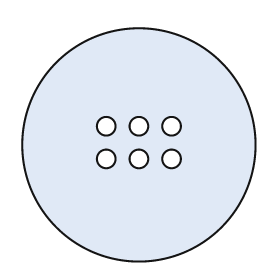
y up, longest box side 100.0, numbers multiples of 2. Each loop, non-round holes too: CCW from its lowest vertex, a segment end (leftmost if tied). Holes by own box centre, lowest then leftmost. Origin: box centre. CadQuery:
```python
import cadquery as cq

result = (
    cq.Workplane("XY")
    .moveTo(0.0, 0.0)
    .circle(50.0)
    .moveTo(-14.0, -6.0)
    .circle(4.0)
    .moveTo(0.0, -6.0)
    .circle(4.0)
    .moveTo(14.0, -6.0)
    .circle(4.0)
    .moveTo(-14.0, 8.0)
    .circle(4.0)
    .moveTo(0.0, 8.0)
    .circle(4.0)
    .moveTo(14.0, 8.0)
    .circle(4.0)
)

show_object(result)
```